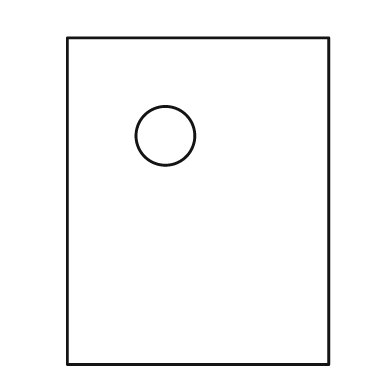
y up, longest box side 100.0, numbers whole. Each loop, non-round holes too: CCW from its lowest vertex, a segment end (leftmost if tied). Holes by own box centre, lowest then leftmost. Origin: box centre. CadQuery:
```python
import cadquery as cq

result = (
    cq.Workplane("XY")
    .moveTo(-40.0, -50.0)
    .lineTo(40.0, -50.0)
    .lineTo(40.0, 50.0)
    .lineTo(-40.0, 50.0)
    .close()
    .moveTo(-10.0, 20.0)
    .circle(9.0)
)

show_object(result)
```